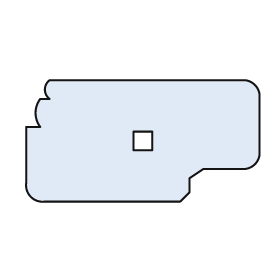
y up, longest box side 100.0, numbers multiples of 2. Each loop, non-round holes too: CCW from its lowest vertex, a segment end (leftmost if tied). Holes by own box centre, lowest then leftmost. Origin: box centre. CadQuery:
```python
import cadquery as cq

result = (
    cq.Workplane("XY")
    .moveTo(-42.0, -26.0)
    .lineTo(16.0, -26.0)
    .lineTo(20.0, -22.0)
    .lineTo(20.0, -16.0)
    .lineTo(26.0, -12.0)
    .lineTo(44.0, -12.0)
    .threePointArc((48.0, -10.0), (50.0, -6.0))
    .lineTo(50.0, 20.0)
    .threePointArc((48.0, 24.0), (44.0, 26.0))
    .lineTo(-40.0, 26.0)
    .threePointArc((-42.0, 22.0), (-40.0, 18.0))
    .lineTo(-44.0, 18.0)
    .threePointArc((-46.0, 12.0), (-44.0, 6.0))
    .lineTo(-50.0, 6.0)
    .lineTo(-50.0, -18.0)
    .threePointArc((-48.0, -24.0), (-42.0, -26.0))
    .close()
    .moveTo(-4.0, -4.0)
    .lineTo(4.0, -4.0)
    .lineTo(4.0, 4.0)
    .lineTo(-4.0, 4.0)
    .close()
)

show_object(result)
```